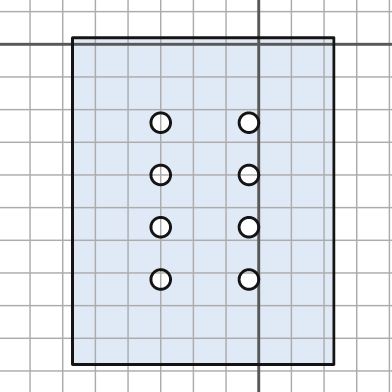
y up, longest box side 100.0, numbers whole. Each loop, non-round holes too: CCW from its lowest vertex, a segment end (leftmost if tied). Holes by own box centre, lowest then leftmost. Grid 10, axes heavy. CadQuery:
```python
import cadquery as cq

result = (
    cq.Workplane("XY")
    .moveTo(-57.0, -98.0)
    .lineTo(23.0, -98.0)
    .lineTo(23.0, 2.0)
    .lineTo(-57.0, 2.0)
    .close()
    .moveTo(-30.0, -72.0)
    .circle(3.0)
    .moveTo(-3.0, -72.0)
    .circle(3.0)
    .moveTo(-30.0, -56.0)
    .circle(3.0)
    .moveTo(-3.0, -56.0)
    .circle(3.0)
    .moveTo(-30.0, -40.0)
    .circle(3.0)
    .moveTo(-3.0, -40.0)
    .circle(3.0)
    .moveTo(-30.0, -24.0)
    .circle(3.0)
    .moveTo(-3.0, -24.0)
    .circle(3.0)
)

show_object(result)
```